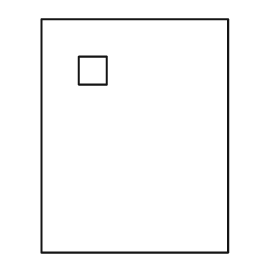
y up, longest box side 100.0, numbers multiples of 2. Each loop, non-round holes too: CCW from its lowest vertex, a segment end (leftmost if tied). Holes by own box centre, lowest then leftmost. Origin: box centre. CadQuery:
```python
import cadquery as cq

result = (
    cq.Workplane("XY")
    .moveTo(-40.0, -50.0)
    .lineTo(40.0, -50.0)
    .lineTo(40.0, 50.0)
    .lineTo(-40.0, 50.0)
    .close()
    .moveTo(-24.0, 22.0)
    .lineTo(-12.0, 22.0)
    .lineTo(-12.0, 34.0)
    .lineTo(-24.0, 34.0)
    .close()
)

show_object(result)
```